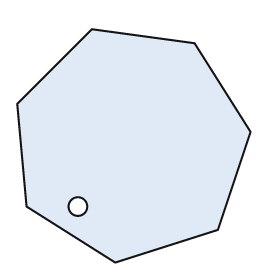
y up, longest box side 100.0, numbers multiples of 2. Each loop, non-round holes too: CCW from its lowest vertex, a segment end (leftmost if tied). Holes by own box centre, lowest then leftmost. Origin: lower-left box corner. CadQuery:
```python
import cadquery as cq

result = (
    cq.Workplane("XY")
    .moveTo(42.0, 0.0)
    .lineTo(86.0, 14.0)
    .lineTo(100.0, 56.0)
    .lineTo(76.0, 94.0)
    .lineTo(32.0, 100.0)
    .lineTo(0.0, 68.0)
    .lineTo(4.0, 24.0)
    .close()
    .moveTo(26.0, 24.0)
    .circle(4.0)
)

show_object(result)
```